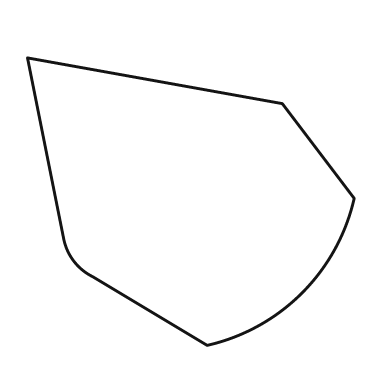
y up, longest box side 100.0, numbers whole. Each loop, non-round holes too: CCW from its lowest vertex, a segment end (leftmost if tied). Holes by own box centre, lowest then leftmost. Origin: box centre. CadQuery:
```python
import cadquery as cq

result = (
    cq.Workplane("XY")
    .moveTo(5.0, -44.0)
    .threePointArc((34.0, -28.0), (50.0, 1.0))
    .lineTo(28.0, 30.0)
    .lineTo(-50.0, 44.0)
    .lineTo(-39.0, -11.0)
    .threePointArc((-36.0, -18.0), (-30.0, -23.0))
    .close()
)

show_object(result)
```